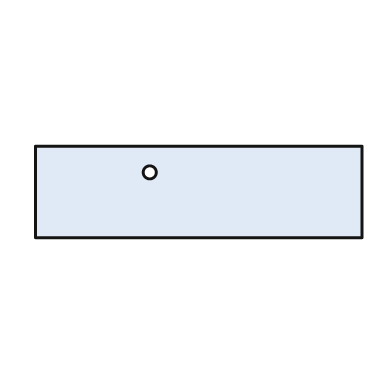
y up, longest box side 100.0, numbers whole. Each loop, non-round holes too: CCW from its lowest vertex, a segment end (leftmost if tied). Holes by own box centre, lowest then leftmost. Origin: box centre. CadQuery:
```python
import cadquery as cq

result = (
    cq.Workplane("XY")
    .moveTo(-50.0, -14.0)
    .lineTo(50.0, -14.0)
    .lineTo(50.0, 14.0)
    .lineTo(-50.0, 14.0)
    .close()
    .moveTo(-15.0, 6.0)
    .circle(2.0)
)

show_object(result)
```